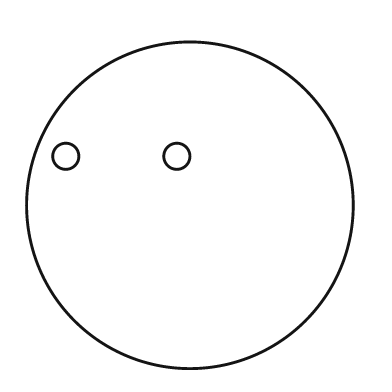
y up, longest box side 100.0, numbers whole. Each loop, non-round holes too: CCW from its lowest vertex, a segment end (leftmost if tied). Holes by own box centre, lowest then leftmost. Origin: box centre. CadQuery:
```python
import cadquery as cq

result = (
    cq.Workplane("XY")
    .moveTo(0.0, 0.0)
    .circle(50.0)
    .moveTo(-38.0, 15.0)
    .circle(4.0)
    .moveTo(-4.0, 15.0)
    .circle(4.0)
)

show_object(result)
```